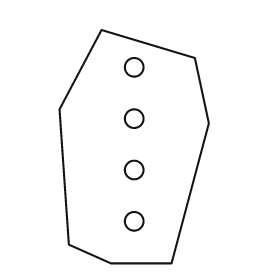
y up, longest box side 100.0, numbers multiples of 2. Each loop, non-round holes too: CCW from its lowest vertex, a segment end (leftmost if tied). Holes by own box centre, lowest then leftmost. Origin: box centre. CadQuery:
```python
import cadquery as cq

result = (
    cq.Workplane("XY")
    .moveTo(-10.0, -50.0)
    .lineTo(16.0, -50.0)
    .lineTo(32.0, 10.0)
    .lineTo(26.0, 38.0)
    .lineTo(-14.0, 50.0)
    .lineTo(-32.0, 16.0)
    .lineTo(-28.0, -42.0)
    .close()
    .moveTo(0.0, -32.0)
    .circle(4.0)
    .moveTo(0.0, -10.0)
    .circle(4.0)
    .moveTo(0.0, 12.0)
    .circle(4.0)
    .moveTo(0.0, 34.0)
    .circle(4.0)
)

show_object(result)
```